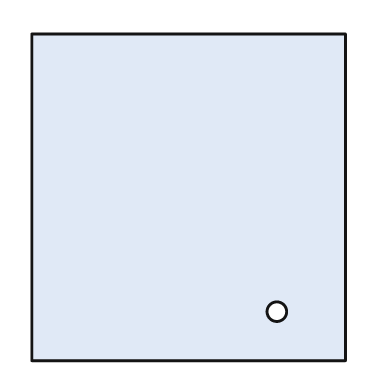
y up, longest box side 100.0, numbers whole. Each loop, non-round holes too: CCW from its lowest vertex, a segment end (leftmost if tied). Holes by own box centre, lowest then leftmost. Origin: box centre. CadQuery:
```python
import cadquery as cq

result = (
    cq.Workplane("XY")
    .moveTo(-48.0, -50.0)
    .lineTo(48.0, -50.0)
    .lineTo(48.0, 50.0)
    .lineTo(-48.0, 50.0)
    .close()
    .moveTo(27.0, -35.0)
    .circle(3.0)
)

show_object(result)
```